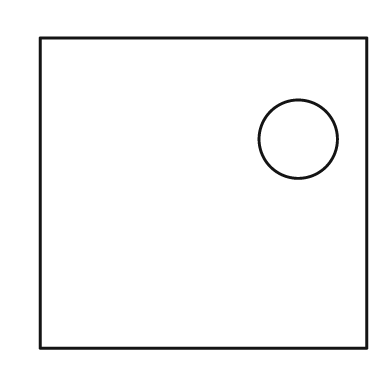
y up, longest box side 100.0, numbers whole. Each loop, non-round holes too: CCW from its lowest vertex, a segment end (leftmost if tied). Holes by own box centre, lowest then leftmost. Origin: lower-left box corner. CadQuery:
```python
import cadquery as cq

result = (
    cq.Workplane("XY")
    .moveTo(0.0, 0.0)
    .lineTo(100.0, 0.0)
    .lineTo(100.0, 95.0)
    .lineTo(0.0, 95.0)
    .close()
    .moveTo(79.0, 64.0)
    .circle(12.0)
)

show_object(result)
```